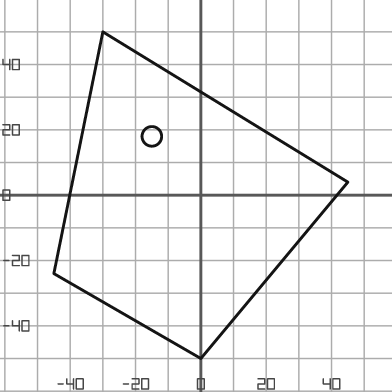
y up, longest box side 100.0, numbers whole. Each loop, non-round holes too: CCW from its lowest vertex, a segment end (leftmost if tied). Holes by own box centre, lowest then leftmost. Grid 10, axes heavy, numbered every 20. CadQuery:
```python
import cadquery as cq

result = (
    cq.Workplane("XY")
    .moveTo(0.0, -50.0)
    .lineTo(45.0, 4.0)
    .lineTo(-30.0, 50.0)
    .lineTo(-45.0, -24.0)
    .close()
    .moveTo(-15.0, 18.0)
    .circle(3.0)
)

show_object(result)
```